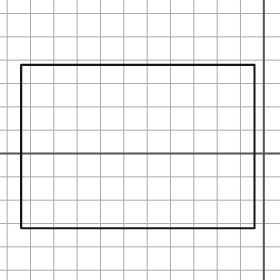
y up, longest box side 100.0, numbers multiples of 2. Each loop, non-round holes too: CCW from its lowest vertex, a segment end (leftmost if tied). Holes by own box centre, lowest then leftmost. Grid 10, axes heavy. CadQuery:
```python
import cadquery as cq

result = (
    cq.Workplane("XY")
    .moveTo(-104.0, -32.0)
    .lineTo(-4.0, -32.0)
    .lineTo(-4.0, 38.0)
    .lineTo(-104.0, 38.0)
    .close()
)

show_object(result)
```